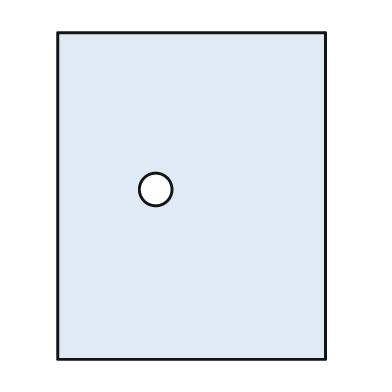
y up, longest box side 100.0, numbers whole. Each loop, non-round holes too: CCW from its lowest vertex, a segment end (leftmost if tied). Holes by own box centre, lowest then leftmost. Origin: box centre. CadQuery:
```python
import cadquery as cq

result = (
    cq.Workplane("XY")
    .moveTo(-41.0, -50.0)
    .lineTo(41.0, -50.0)
    .lineTo(41.0, 50.0)
    .lineTo(-41.0, 50.0)
    .close()
    .moveTo(-11.0, 2.0)
    .circle(5.0)
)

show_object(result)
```